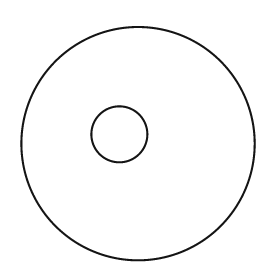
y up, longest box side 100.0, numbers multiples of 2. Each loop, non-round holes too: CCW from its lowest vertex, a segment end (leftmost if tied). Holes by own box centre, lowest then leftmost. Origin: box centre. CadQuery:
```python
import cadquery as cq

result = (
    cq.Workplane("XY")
    .moveTo(0.0, 0.0)
    .circle(50.0)
    .moveTo(-8.0, 4.0)
    .circle(12.0)
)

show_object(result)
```